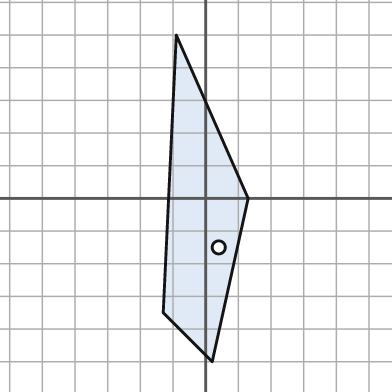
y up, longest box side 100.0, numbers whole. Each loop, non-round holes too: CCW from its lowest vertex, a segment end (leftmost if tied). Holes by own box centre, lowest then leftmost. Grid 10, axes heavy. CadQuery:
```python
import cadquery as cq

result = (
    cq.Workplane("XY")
    .moveTo(2.0, -50.0)
    .lineTo(13.0, 0.0)
    .lineTo(-9.0, 50.0)
    .lineTo(-13.0, -35.0)
    .close()
    .moveTo(4.0, -15.0)
    .circle(2.0)
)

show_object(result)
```